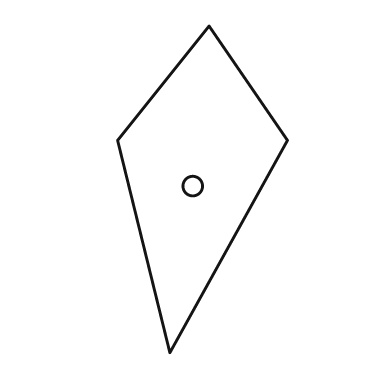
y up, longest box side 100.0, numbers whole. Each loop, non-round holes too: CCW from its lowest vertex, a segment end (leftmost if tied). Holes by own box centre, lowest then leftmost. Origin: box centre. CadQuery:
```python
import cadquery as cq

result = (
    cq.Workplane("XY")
    .moveTo(-10.0, -50.0)
    .lineTo(26.0, 15.0)
    .lineTo(2.0, 50.0)
    .lineTo(-26.0, 15.0)
    .close()
    .moveTo(-3.0, 1.0)
    .circle(3.0)
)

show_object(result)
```